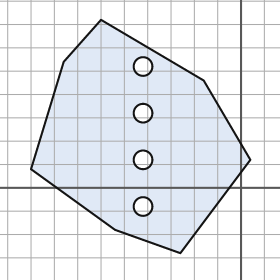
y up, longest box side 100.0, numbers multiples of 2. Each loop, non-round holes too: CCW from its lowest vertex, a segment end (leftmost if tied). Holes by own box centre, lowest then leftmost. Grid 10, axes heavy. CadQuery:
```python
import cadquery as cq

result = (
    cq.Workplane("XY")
    .moveTo(-26.0, -28.0)
    .lineTo(4.0, 12.0)
    .lineTo(-16.0, 46.0)
    .lineTo(-60.0, 72.0)
    .lineTo(-76.0, 54.0)
    .lineTo(-90.0, 8.0)
    .lineTo(-54.0, -18.0)
    .close()
    .moveTo(-42.0, -8.0)
    .circle(4.0)
    .moveTo(-42.0, 12.0)
    .circle(4.0)
    .moveTo(-42.0, 32.0)
    .circle(4.0)
    .moveTo(-42.0, 52.0)
    .circle(4.0)
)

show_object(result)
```